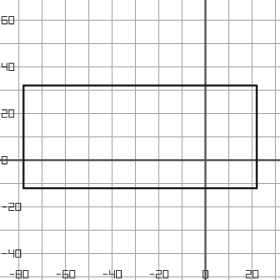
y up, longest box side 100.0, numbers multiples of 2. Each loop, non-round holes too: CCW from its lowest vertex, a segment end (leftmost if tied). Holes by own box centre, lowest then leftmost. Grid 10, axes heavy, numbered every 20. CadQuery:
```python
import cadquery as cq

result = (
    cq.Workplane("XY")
    .moveTo(-78.0, -12.0)
    .lineTo(22.0, -12.0)
    .lineTo(22.0, 32.0)
    .lineTo(-78.0, 32.0)
    .close()
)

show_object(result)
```